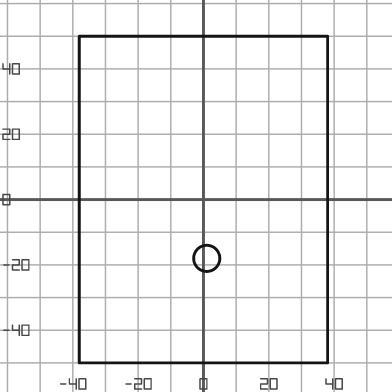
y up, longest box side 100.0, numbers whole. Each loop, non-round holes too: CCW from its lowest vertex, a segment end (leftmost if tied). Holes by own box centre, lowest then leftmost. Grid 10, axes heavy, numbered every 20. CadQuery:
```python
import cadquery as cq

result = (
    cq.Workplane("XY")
    .moveTo(-38.0, -50.0)
    .lineTo(38.0, -50.0)
    .lineTo(38.0, 50.0)
    .lineTo(-38.0, 50.0)
    .close()
    .moveTo(1.0, -18.0)
    .circle(4.0)
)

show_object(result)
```